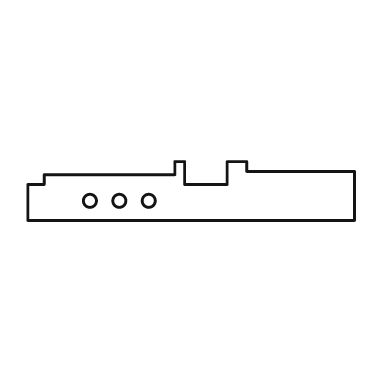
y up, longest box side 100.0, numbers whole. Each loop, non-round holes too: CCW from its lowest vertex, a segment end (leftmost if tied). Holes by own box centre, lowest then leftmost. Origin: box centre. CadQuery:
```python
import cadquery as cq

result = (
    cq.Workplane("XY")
    .moveTo(-50.0, -9.0)
    .lineTo(50.0, -9.0)
    .lineTo(50.0, 6.0)
    .lineTo(17.0, 6.0)
    .lineTo(17.0, 9.0)
    .lineTo(11.0, 9.0)
    .lineTo(11.0, 2.0)
    .lineTo(-2.0, 2.0)
    .lineTo(-2.0, 9.0)
    .lineTo(-5.0, 9.0)
    .lineTo(-5.0, 5.0)
    .lineTo(-45.0, 5.0)
    .lineTo(-45.0, 2.0)
    .lineTo(-50.0, 2.0)
    .close()
    .moveTo(-31.0, -3.0)
    .circle(2.0)
    .moveTo(-22.0, -3.0)
    .circle(2.0)
    .moveTo(-13.0, -3.0)
    .circle(2.0)
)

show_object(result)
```